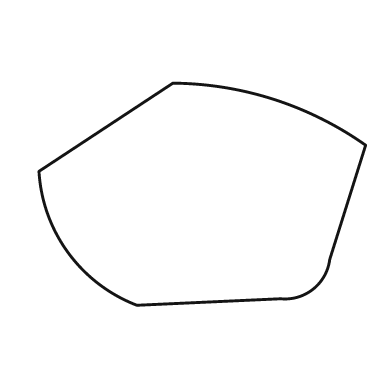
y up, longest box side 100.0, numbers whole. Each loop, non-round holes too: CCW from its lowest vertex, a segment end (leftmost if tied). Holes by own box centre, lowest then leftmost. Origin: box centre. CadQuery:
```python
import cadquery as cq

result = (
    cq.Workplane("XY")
    .moveTo(-20.0, -34.0)
    .lineTo(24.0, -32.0)
    .threePointArc((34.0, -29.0), (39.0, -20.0))
    .lineTo(50.0, 15.0)
    .threePointArc((22.0, 29.0), (-9.0, 34.0))
    .lineTo(-50.0, 7.0)
    .threePointArc((-41.0, -18.0), (-20.0, -34.0))
    .close()
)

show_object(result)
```